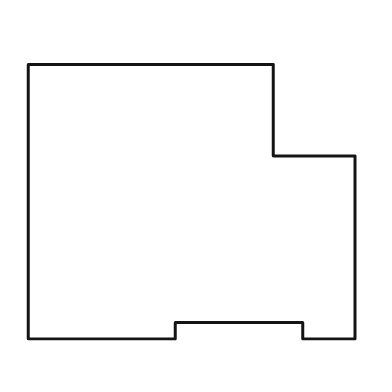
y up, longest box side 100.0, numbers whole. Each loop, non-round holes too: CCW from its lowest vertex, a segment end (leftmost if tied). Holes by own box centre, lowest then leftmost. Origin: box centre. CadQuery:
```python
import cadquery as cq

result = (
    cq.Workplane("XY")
    .moveTo(-50.0, -42.0)
    .lineTo(-5.0, -42.0)
    .lineTo(-5.0, -37.0)
    .lineTo(34.0, -37.0)
    .lineTo(34.0, -42.0)
    .lineTo(50.0, -42.0)
    .lineTo(50.0, 14.0)
    .lineTo(25.0, 14.0)
    .lineTo(25.0, 42.0)
    .lineTo(-50.0, 42.0)
    .close()
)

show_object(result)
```